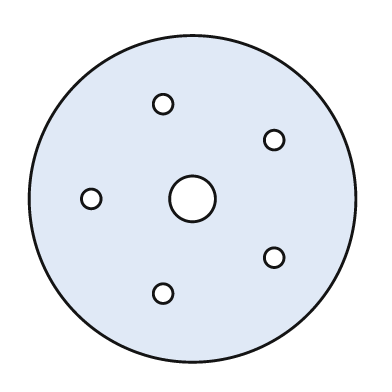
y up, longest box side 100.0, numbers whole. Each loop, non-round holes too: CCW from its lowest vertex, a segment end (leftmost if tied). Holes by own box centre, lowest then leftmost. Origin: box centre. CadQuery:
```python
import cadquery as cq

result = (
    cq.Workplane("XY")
    .moveTo(0.0, 0.0)
    .circle(50.0)
    .moveTo(-9.0, -29.0)
    .circle(3.0)
    .moveTo(25.0, -18.0)
    .circle(3.0)
    .moveTo(-31.0, 0.0)
    .circle(3.0)
    .moveTo(0.0, 0.0)
    .circle(7.0)
    .moveTo(25.0, 18.0)
    .circle(3.0)
    .moveTo(-9.0, 29.0)
    .circle(3.0)
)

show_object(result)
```